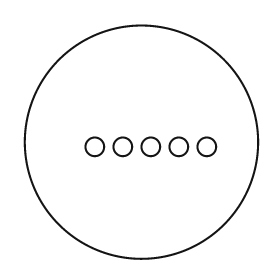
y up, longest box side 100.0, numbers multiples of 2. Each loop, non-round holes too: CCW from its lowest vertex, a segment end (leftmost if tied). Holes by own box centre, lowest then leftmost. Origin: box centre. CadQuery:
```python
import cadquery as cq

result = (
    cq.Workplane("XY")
    .moveTo(0.0, 0.0)
    .circle(50.0)
    .moveTo(-20.0, -2.0)
    .circle(4.0)
    .moveTo(-8.0, -2.0)
    .circle(4.0)
    .moveTo(4.0, -2.0)
    .circle(4.0)
    .moveTo(16.0, -2.0)
    .circle(4.0)
    .moveTo(28.0, -2.0)
    .circle(4.0)
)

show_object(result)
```